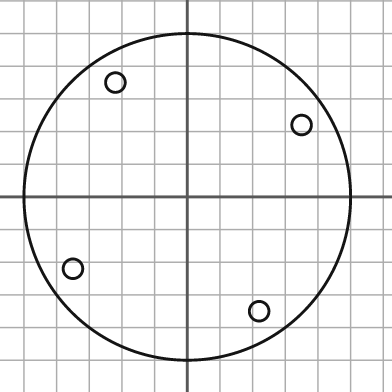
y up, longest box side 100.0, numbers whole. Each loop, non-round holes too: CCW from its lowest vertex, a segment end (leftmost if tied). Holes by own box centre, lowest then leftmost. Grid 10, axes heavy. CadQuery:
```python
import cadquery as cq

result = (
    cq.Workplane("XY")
    .moveTo(0.0, 0.0)
    .circle(50.0)
    .moveTo(22.0, -35.0)
    .circle(3.0)
    .moveTo(-35.0, -22.0)
    .circle(3.0)
    .moveTo(35.0, 22.0)
    .circle(3.0)
    .moveTo(-22.0, 35.0)
    .circle(3.0)
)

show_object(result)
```